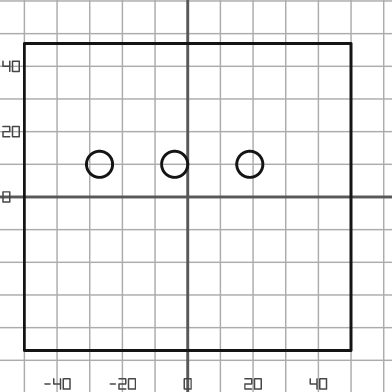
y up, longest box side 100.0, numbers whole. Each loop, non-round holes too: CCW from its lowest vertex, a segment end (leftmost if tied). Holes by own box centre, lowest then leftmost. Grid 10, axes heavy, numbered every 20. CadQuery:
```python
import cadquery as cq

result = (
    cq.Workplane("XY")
    .moveTo(-50.0, -47.0)
    .lineTo(50.0, -47.0)
    .lineTo(50.0, 47.0)
    .lineTo(-50.0, 47.0)
    .close()
    .moveTo(-27.0, 10.0)
    .circle(4.0)
    .moveTo(-4.0, 10.0)
    .circle(4.0)
    .moveTo(19.0, 10.0)
    .circle(4.0)
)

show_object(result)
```